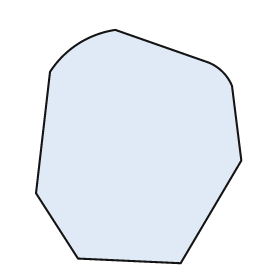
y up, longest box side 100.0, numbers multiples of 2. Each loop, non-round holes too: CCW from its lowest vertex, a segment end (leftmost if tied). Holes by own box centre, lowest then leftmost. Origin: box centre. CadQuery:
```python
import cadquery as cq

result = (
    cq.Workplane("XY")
    .moveTo(18.0, -50.0)
    .lineTo(44.0, -6.0)
    .lineTo(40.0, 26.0)
    .threePointArc((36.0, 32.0), (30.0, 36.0))
    .lineTo(-10.0, 50.0)
    .threePointArc((-26.0, 44.0), (-38.0, 32.0))
    .lineTo(-44.0, -20.0)
    .lineTo(-26.0, -48.0)
    .close()
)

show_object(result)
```